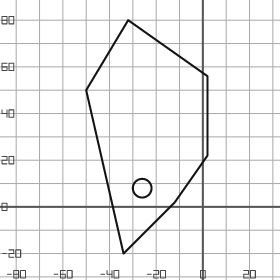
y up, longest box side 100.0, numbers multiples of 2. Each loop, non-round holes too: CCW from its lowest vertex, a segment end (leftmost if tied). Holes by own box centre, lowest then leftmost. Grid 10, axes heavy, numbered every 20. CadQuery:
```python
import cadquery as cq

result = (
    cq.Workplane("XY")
    .moveTo(-34.0, -20.0)
    .lineTo(-12.0, 2.0)
    .lineTo(2.0, 22.0)
    .lineTo(2.0, 56.0)
    .lineTo(-32.0, 80.0)
    .lineTo(-50.0, 50.0)
    .close()
    .moveTo(-26.0, 8.0)
    .circle(4.0)
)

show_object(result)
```